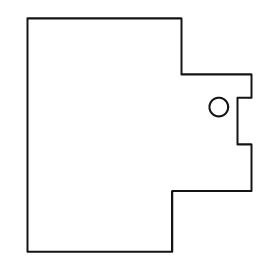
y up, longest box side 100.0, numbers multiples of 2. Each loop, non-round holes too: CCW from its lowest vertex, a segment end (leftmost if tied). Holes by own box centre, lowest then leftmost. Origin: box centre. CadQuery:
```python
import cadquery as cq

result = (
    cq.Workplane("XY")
    .moveTo(-48.0, -50.0)
    .lineTo(14.0, -50.0)
    .lineTo(14.0, -24.0)
    .lineTo(48.0, -24.0)
    .lineTo(48.0, -4.0)
    .lineTo(42.0, -4.0)
    .lineTo(42.0, 16.0)
    .lineTo(48.0, 16.0)
    .lineTo(48.0, 26.0)
    .lineTo(18.0, 26.0)
    .lineTo(18.0, 50.0)
    .lineTo(-48.0, 50.0)
    .close()
    .moveTo(34.0, 12.0)
    .circle(4.0)
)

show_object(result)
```